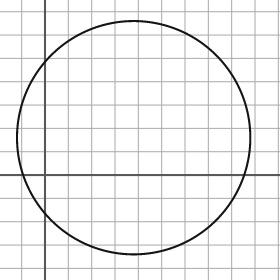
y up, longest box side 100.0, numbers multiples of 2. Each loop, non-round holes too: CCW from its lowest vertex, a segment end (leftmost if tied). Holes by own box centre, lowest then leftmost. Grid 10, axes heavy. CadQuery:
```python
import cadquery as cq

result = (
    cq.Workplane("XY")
    .moveTo(38.0, 16.0)
    .circle(50.0)
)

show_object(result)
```